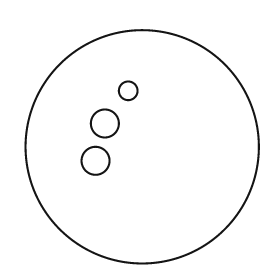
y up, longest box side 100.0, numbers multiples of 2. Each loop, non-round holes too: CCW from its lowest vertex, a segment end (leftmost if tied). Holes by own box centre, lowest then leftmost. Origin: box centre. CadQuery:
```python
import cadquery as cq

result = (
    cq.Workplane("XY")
    .moveTo(0.0, 0.0)
    .circle(50.0)
    .moveTo(-20.0, -6.0)
    .circle(6.0)
    .moveTo(-16.0, 10.0)
    .circle(6.0)
    .moveTo(-6.0, 24.0)
    .circle(4.0)
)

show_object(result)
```